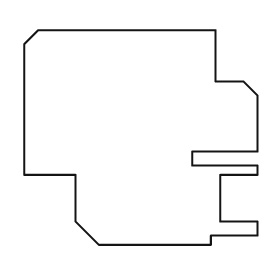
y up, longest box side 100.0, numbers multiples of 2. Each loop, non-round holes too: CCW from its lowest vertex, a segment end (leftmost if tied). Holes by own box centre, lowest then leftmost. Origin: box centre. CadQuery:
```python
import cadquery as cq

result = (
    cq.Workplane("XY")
    .moveTo(-18.0, -46.0)
    .lineTo(30.0, -46.0)
    .lineTo(30.0, -42.0)
    .lineTo(50.0, -42.0)
    .lineTo(50.0, -36.0)
    .lineTo(34.0, -36.0)
    .lineTo(34.0, -16.0)
    .lineTo(50.0, -16.0)
    .lineTo(50.0, -12.0)
    .lineTo(22.0, -12.0)
    .lineTo(22.0, -6.0)
    .lineTo(50.0, -6.0)
    .lineTo(50.0, 18.0)
    .lineTo(44.0, 24.0)
    .lineTo(32.0, 24.0)
    .lineTo(32.0, 46.0)
    .lineTo(-44.0, 46.0)
    .lineTo(-50.0, 40.0)
    .lineTo(-50.0, -16.0)
    .lineTo(-28.0, -16.0)
    .lineTo(-28.0, -36.0)
    .close()
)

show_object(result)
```